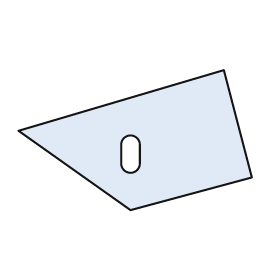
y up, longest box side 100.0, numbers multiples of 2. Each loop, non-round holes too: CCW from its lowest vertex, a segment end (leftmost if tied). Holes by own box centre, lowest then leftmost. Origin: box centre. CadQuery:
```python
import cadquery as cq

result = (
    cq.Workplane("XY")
    .moveTo(-2.0, -30.0)
    .lineTo(50.0, -16.0)
    .lineTo(38.0, 30.0)
    .lineTo(-50.0, 4.0)
    .close()
    .moveTo(-6.0, -10.0)
    .threePointArc((-2.0, -14.0), (2.0, -10.0))
    .lineTo(2.0, -2.0)
    .threePointArc((-2.0, 2.0), (-6.0, -2.0))
    .close()
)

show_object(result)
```